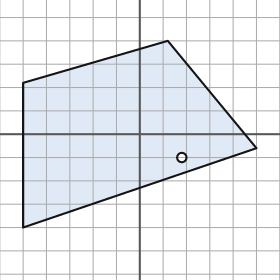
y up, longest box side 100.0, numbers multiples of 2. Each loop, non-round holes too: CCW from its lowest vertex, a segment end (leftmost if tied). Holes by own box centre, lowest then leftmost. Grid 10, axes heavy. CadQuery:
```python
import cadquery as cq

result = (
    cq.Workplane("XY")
    .moveTo(-50.0, -40.0)
    .lineTo(50.0, -6.0)
    .lineTo(12.0, 40.0)
    .lineTo(-50.0, 22.0)
    .close()
    .moveTo(18.0, -10.0)
    .circle(2.0)
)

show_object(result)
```